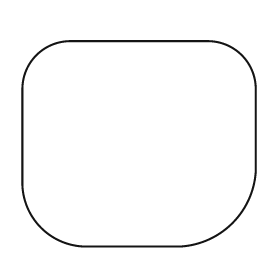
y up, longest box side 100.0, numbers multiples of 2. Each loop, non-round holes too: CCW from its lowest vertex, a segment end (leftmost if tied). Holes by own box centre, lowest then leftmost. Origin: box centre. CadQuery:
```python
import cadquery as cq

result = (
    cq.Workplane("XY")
    .moveTo(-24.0, -44.0)
    .lineTo(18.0, -44.0)
    .threePointArc((40.0, -34.0), (50.0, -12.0))
    .lineTo(50.0, 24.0)
    .threePointArc((44.0, 38.0), (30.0, 44.0))
    .lineTo(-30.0, 44.0)
    .threePointArc((-44.0, 38.0), (-50.0, 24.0))
    .lineTo(-50.0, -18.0)
    .threePointArc((-42.0, -36.0), (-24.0, -44.0))
    .close()
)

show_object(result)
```